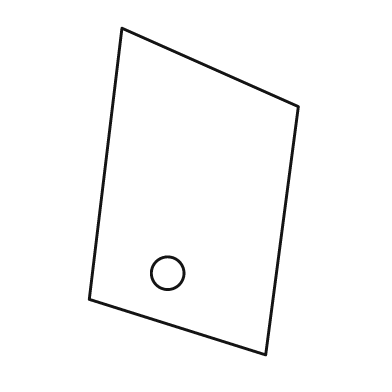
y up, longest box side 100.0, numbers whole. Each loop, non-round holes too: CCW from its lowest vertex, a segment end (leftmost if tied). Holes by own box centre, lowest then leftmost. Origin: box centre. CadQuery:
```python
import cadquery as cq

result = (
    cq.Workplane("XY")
    .moveTo(22.0, -50.0)
    .lineTo(32.0, 26.0)
    .lineTo(-22.0, 50.0)
    .lineTo(-32.0, -33.0)
    .close()
    .moveTo(-8.0, -25.0)
    .circle(5.0)
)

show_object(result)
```